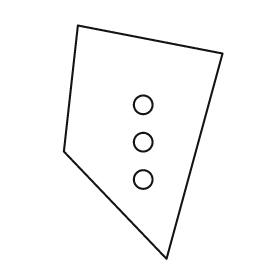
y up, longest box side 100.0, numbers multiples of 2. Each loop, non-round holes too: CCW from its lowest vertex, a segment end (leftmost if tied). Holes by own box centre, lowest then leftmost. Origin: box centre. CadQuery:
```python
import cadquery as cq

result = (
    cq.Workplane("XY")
    .moveTo(10.0, -50.0)
    .lineTo(34.0, 38.0)
    .lineTo(-28.0, 50.0)
    .lineTo(-34.0, -4.0)
    .close()
    .moveTo(0.0, -16.0)
    .circle(4.0)
    .moveTo(0.0, 0.0)
    .circle(4.0)
    .moveTo(0.0, 16.0)
    .circle(4.0)
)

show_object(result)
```